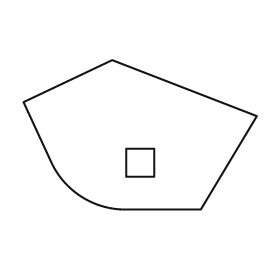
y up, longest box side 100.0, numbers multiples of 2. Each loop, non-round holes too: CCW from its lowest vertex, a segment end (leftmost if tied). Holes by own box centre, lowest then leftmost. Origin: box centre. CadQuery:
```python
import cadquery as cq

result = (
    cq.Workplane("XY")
    .moveTo(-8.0, -32.0)
    .lineTo(26.0, -32.0)
    .lineTo(50.0, 8.0)
    .lineTo(-12.0, 32.0)
    .lineTo(-50.0, 14.0)
    .lineTo(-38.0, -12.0)
    .threePointArc((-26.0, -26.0), (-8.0, -32.0))
    .close()
    .moveTo(-6.0, -18.0)
    .lineTo(6.0, -18.0)
    .lineTo(6.0, -6.0)
    .lineTo(-6.0, -6.0)
    .close()
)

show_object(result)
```